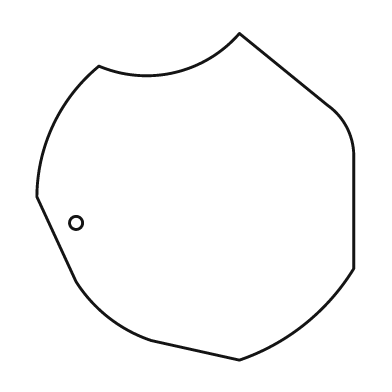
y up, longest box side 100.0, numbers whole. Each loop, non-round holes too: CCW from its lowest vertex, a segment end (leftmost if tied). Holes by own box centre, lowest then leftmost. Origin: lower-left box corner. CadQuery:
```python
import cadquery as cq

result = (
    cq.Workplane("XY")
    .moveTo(62.0, 0.0)
    .threePointArc((82.0, 11.0), (97.0, 28.0))
    .lineTo(97.0, 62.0)
    .threePointArc((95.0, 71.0), (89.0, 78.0))
    .lineTo(62.0, 100.0)
    .threePointArc((42.0, 88.0), (19.0, 90.0))
    .threePointArc((5.0, 72.0), (0.0, 50.0))
    .lineTo(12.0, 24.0)
    .threePointArc((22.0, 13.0), (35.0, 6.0))
    .close()
    .moveTo(12.0, 42.0)
    .circle(2.0)
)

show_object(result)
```